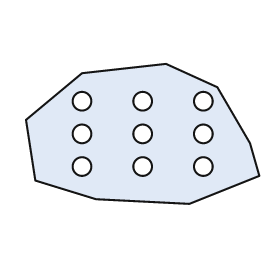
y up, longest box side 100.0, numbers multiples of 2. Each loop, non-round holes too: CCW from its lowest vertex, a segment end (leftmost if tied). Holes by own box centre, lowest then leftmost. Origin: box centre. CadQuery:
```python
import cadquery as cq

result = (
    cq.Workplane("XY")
    .moveTo(20.0, -30.0)
    .lineTo(50.0, -18.0)
    .lineTo(46.0, -4.0)
    .lineTo(32.0, 20.0)
    .lineTo(10.0, 30.0)
    .lineTo(-26.0, 26.0)
    .lineTo(-50.0, 6.0)
    .lineTo(-46.0, -20.0)
    .lineTo(-20.0, -28.0)
    .close()
    .moveTo(-26.0, -14.0)
    .circle(4.0)
    .moveTo(0.0, -14.0)
    .circle(4.0)
    .moveTo(26.0, -14.0)
    .circle(4.0)
    .moveTo(-26.0, 0.0)
    .circle(4.0)
    .moveTo(0.0, 0.0)
    .circle(4.0)
    .moveTo(26.0, 0.0)
    .circle(4.0)
    .moveTo(-26.0, 14.0)
    .circle(4.0)
    .moveTo(0.0, 14.0)
    .circle(4.0)
    .moveTo(26.0, 14.0)
    .circle(4.0)
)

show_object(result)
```